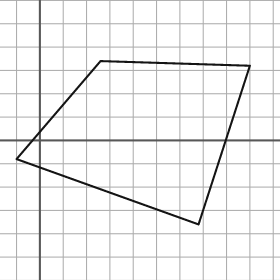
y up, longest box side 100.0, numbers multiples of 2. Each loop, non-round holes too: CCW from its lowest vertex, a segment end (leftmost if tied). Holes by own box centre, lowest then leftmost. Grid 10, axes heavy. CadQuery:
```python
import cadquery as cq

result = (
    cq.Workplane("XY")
    .moveTo(68.0, -36.0)
    .lineTo(90.0, 32.0)
    .lineTo(26.0, 34.0)
    .lineTo(-10.0, -8.0)
    .close()
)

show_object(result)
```